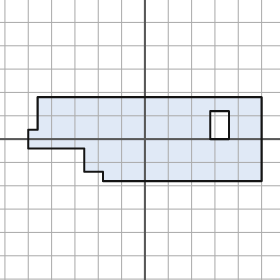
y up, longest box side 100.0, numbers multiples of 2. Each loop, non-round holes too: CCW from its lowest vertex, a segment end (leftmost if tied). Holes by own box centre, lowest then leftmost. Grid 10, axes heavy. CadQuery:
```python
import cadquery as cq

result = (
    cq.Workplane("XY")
    .moveTo(-18.0, -18.0)
    .lineTo(50.0, -18.0)
    .lineTo(50.0, 18.0)
    .lineTo(-46.0, 18.0)
    .lineTo(-46.0, 4.0)
    .lineTo(-50.0, 4.0)
    .lineTo(-50.0, -4.0)
    .lineTo(-26.0, -4.0)
    .lineTo(-26.0, -14.0)
    .lineTo(-18.0, -14.0)
    .close()
    .moveTo(28.0, 0.0)
    .lineTo(36.0, 0.0)
    .lineTo(36.0, 12.0)
    .lineTo(28.0, 12.0)
    .close()
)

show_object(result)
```